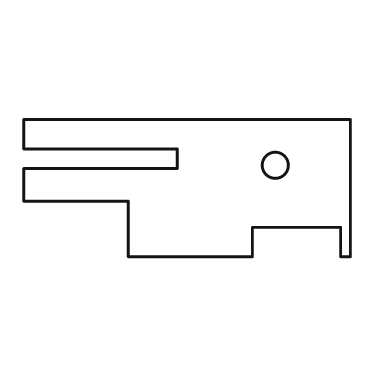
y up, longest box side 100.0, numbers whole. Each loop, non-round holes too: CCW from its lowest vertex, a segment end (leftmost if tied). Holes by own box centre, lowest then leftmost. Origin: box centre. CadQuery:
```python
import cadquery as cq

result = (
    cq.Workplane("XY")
    .moveTo(-18.0, -21.0)
    .lineTo(20.0, -21.0)
    .lineTo(20.0, -12.0)
    .lineTo(47.0, -12.0)
    .lineTo(47.0, -21.0)
    .lineTo(50.0, -21.0)
    .lineTo(50.0, 21.0)
    .lineTo(-50.0, 21.0)
    .lineTo(-50.0, 12.0)
    .lineTo(-3.0, 12.0)
    .lineTo(-3.0, 6.0)
    .lineTo(-50.0, 6.0)
    .lineTo(-50.0, -4.0)
    .lineTo(-18.0, -4.0)
    .close()
    .moveTo(27.0, 7.0)
    .circle(4.0)
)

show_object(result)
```